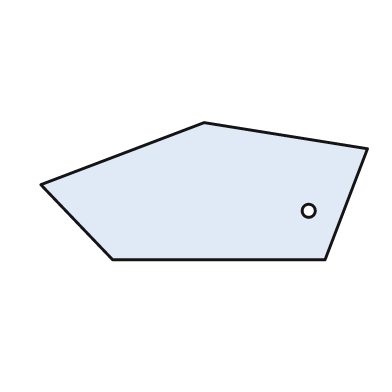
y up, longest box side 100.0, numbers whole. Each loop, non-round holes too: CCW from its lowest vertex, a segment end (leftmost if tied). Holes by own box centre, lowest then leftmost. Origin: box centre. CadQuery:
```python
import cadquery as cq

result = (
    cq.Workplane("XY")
    .moveTo(-28.0, -21.0)
    .lineTo(37.0, -21.0)
    .lineTo(50.0, 13.0)
    .lineTo(0.0, 21.0)
    .lineTo(-50.0, 2.0)
    .close()
    .moveTo(32.0, -6.0)
    .circle(2.0)
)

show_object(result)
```